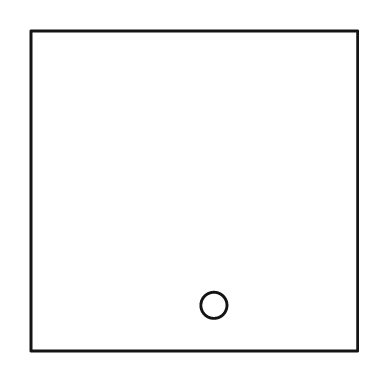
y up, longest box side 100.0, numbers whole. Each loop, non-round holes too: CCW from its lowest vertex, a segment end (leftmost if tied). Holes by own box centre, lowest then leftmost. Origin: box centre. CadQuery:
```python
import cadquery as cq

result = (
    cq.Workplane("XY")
    .moveTo(-50.0, -49.0)
    .lineTo(50.0, -49.0)
    .lineTo(50.0, 49.0)
    .lineTo(-50.0, 49.0)
    .close()
    .moveTo(6.0, -35.0)
    .circle(4.0)
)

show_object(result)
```